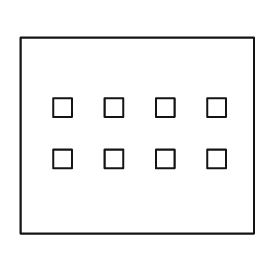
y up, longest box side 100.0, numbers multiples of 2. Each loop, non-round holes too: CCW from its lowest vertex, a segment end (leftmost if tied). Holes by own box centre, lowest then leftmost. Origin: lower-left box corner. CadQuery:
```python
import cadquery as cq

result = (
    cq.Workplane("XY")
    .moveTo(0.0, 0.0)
    .lineTo(100.0, 0.0)
    .lineTo(100.0, 84.0)
    .lineTo(0.0, 84.0)
    .close()
    .moveTo(14.0, 28.0)
    .lineTo(22.0, 28.0)
    .lineTo(22.0, 36.0)
    .lineTo(14.0, 36.0)
    .close()
    .moveTo(36.0, 28.0)
    .lineTo(44.0, 28.0)
    .lineTo(44.0, 36.0)
    .lineTo(36.0, 36.0)
    .close()
    .moveTo(58.0, 28.0)
    .lineTo(66.0, 28.0)
    .lineTo(66.0, 36.0)
    .lineTo(58.0, 36.0)
    .close()
    .moveTo(80.0, 28.0)
    .lineTo(88.0, 28.0)
    .lineTo(88.0, 36.0)
    .lineTo(80.0, 36.0)
    .close()
    .moveTo(14.0, 50.0)
    .lineTo(22.0, 50.0)
    .lineTo(22.0, 58.0)
    .lineTo(14.0, 58.0)
    .close()
    .moveTo(36.0, 50.0)
    .lineTo(44.0, 50.0)
    .lineTo(44.0, 58.0)
    .lineTo(36.0, 58.0)
    .close()
    .moveTo(58.0, 50.0)
    .lineTo(66.0, 50.0)
    .lineTo(66.0, 58.0)
    .lineTo(58.0, 58.0)
    .close()
    .moveTo(80.0, 50.0)
    .lineTo(88.0, 50.0)
    .lineTo(88.0, 58.0)
    .lineTo(80.0, 58.0)
    .close()
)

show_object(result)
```